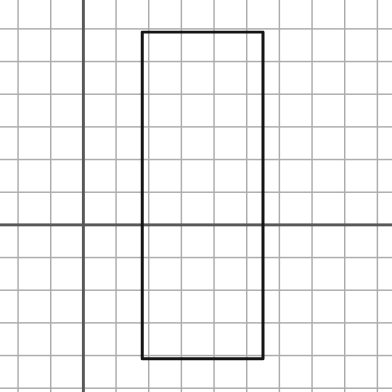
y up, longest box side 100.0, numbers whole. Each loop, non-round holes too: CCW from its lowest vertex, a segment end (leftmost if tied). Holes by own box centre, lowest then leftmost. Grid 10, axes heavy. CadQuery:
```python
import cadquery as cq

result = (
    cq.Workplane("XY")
    .moveTo(18.0, -41.0)
    .lineTo(55.0, -41.0)
    .lineTo(55.0, 59.0)
    .lineTo(18.0, 59.0)
    .close()
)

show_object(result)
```